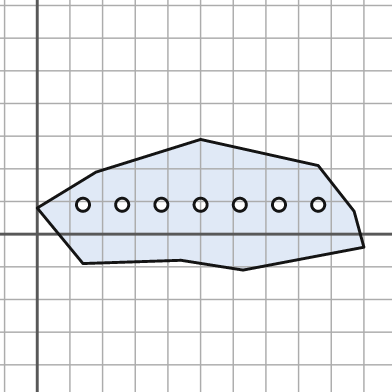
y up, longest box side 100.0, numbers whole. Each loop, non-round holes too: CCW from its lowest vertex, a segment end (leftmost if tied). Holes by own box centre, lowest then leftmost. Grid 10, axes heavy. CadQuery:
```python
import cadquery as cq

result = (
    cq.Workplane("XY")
    .moveTo(63.0, -11.0)
    .lineTo(100.0, -4.0)
    .lineTo(97.0, 7.0)
    .lineTo(86.0, 21.0)
    .lineTo(50.0, 29.0)
    .lineTo(18.0, 19.0)
    .lineTo(0.0, 8.0)
    .lineTo(14.0, -9.0)
    .lineTo(44.0, -8.0)
    .close()
    .moveTo(14.0, 9.0)
    .circle(2.0)
    .moveTo(26.0, 9.0)
    .circle(2.0)
    .moveTo(38.0, 9.0)
    .circle(2.0)
    .moveTo(50.0, 9.0)
    .circle(2.0)
    .moveTo(62.0, 9.0)
    .circle(2.0)
    .moveTo(74.0, 9.0)
    .circle(2.0)
    .moveTo(86.0, 9.0)
    .circle(2.0)
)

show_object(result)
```